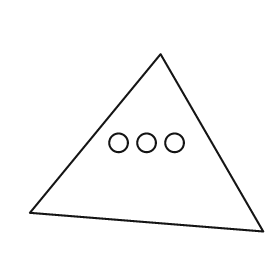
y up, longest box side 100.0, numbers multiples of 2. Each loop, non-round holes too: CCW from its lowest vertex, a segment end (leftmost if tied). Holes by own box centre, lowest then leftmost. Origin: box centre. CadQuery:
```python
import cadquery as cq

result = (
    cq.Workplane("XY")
    .moveTo(50.0, -38.0)
    .lineTo(6.0, 38.0)
    .lineTo(-50.0, -30.0)
    .close()
    .moveTo(-12.0, 0.0)
    .circle(4.0)
    .moveTo(0.0, 0.0)
    .circle(4.0)
    .moveTo(12.0, 0.0)
    .circle(4.0)
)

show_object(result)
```